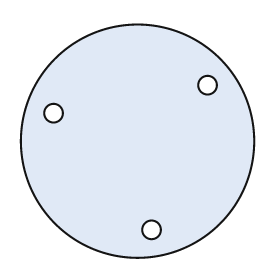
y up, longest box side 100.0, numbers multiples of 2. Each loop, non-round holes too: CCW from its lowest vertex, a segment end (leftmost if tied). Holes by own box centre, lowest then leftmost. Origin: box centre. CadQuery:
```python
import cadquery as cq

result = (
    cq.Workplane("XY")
    .moveTo(0.0, 0.0)
    .circle(50.0)
    .moveTo(6.0, -38.0)
    .circle(4.0)
    .moveTo(-36.0, 12.0)
    .circle(4.0)
    .moveTo(30.0, 24.0)
    .circle(4.0)
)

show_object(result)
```